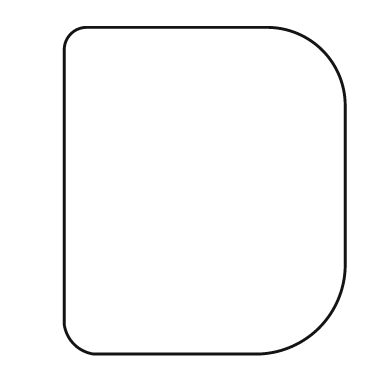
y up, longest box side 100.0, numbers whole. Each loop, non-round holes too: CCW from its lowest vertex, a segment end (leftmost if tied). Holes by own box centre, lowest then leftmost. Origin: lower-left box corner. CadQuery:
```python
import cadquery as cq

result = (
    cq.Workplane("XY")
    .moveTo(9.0, 0.0)
    .lineTo(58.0, 0.0)
    .threePointArc((78.0, 8.0), (86.0, 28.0))
    .lineTo(86.0, 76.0)
    .threePointArc((79.0, 93.0), (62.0, 100.0))
    .lineTo(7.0, 100.0)
    .threePointArc((2.0, 98.0), (0.0, 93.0))
    .lineTo(0.0, 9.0)
    .threePointArc((3.0, 3.0), (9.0, 0.0))
    .close()
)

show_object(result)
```